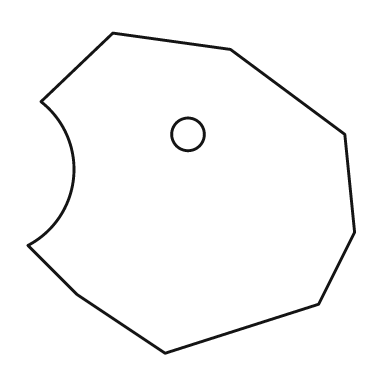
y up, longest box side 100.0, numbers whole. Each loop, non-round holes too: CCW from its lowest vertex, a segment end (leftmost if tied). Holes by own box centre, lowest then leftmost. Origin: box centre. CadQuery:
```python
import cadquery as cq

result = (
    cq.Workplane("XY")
    .moveTo(-8.0, -49.0)
    .lineTo(39.0, -34.0)
    .lineTo(50.0, -12.0)
    .lineTo(47.0, 18.0)
    .lineTo(12.0, 44.0)
    .lineTo(-24.0, 49.0)
    .lineTo(-46.0, 28.0)
    .threePointArc((-36.0, 5.0), (-50.0, -16.0))
    .lineTo(-35.0, -31.0)
    .close()
    .moveTo(-1.0, 18.0)
    .circle(5.0)
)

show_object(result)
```